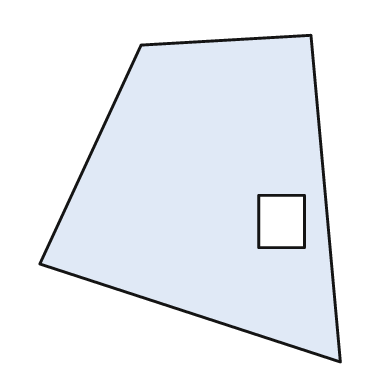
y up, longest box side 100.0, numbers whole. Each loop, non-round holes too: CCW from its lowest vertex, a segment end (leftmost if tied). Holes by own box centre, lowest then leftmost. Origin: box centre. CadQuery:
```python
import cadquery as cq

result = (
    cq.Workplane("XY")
    .moveTo(46.0, -50.0)
    .lineTo(37.0, 50.0)
    .lineTo(-15.0, 47.0)
    .lineTo(-46.0, -20.0)
    .close()
    .moveTo(21.0, -15.0)
    .lineTo(35.0, -15.0)
    .lineTo(35.0, 1.0)
    .lineTo(21.0, 1.0)
    .close()
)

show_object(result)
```